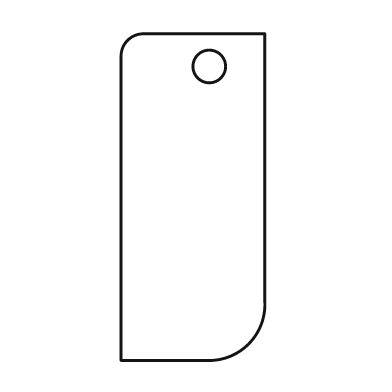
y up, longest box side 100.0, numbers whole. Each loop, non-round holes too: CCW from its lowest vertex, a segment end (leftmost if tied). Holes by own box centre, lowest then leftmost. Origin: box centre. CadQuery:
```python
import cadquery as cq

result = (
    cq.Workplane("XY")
    .moveTo(-22.0, -50.0)
    .lineTo(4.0, -50.0)
    .threePointArc((17.0, -45.0), (22.0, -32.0))
    .lineTo(22.0, 50.0)
    .lineTo(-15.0, 50.0)
    .threePointArc((-20.0, 48.0), (-22.0, 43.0))
    .close()
    .moveTo(5.0, 40.0)
    .circle(5.0)
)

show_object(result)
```